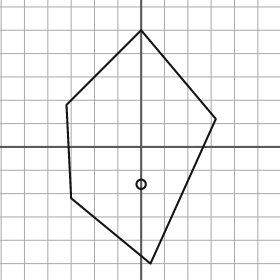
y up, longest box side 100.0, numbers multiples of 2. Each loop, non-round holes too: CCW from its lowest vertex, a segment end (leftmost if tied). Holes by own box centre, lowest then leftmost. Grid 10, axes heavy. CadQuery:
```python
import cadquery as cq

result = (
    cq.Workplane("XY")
    .moveTo(4.0, -50.0)
    .lineTo(32.0, 12.0)
    .lineTo(0.0, 50.0)
    .lineTo(-32.0, 18.0)
    .lineTo(-30.0, -22.0)
    .close()
    .moveTo(0.0, -16.0)
    .circle(2.0)
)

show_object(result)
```